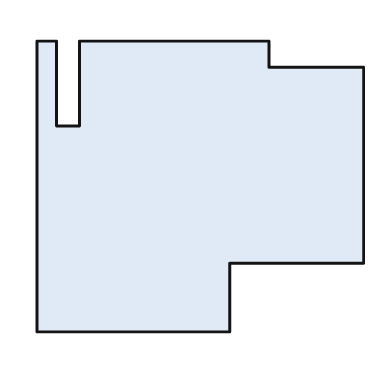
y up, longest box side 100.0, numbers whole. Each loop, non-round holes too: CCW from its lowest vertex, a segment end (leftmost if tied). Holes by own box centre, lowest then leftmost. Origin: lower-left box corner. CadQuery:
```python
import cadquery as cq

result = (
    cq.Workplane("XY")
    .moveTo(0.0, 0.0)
    .lineTo(59.0, 0.0)
    .lineTo(59.0, 21.0)
    .lineTo(100.0, 21.0)
    .lineTo(100.0, 81.0)
    .lineTo(71.0, 81.0)
    .lineTo(71.0, 89.0)
    .lineTo(13.0, 89.0)
    .lineTo(13.0, 63.0)
    .lineTo(6.0, 63.0)
    .lineTo(6.0, 89.0)
    .lineTo(0.0, 89.0)
    .close()
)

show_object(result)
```